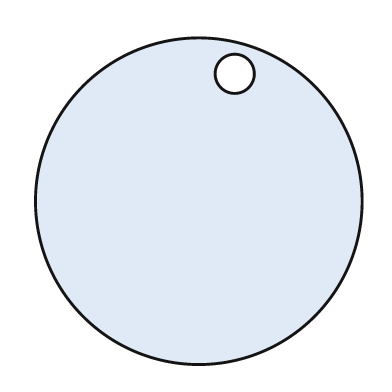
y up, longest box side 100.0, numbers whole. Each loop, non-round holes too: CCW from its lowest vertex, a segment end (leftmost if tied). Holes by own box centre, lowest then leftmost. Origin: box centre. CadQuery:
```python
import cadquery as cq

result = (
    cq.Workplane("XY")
    .moveTo(0.0, 0.0)
    .circle(50.0)
    .moveTo(11.0, 39.0)
    .circle(6.0)
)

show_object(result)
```